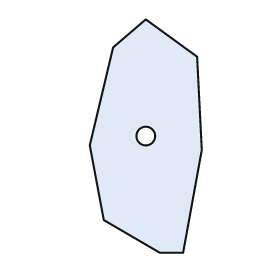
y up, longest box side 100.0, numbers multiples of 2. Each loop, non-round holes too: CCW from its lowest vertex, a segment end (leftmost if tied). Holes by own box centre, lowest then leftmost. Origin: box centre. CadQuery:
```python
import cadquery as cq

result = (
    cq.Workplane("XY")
    .moveTo(6.0, -50.0)
    .lineTo(16.0, -50.0)
    .lineTo(24.0, -6.0)
    .lineTo(22.0, 34.0)
    .lineTo(0.0, 50.0)
    .lineTo(-14.0, 38.0)
    .lineTo(-24.0, -4.0)
    .lineTo(-18.0, -36.0)
    .close()
    .moveTo(0.0, 0.0)
    .circle(4.0)
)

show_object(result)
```